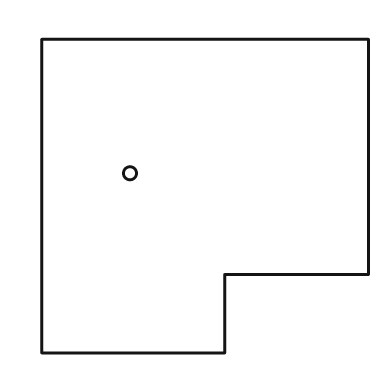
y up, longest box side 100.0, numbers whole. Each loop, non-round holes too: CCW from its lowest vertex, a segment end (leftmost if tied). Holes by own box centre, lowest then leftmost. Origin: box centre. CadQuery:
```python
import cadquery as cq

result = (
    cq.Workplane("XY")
    .moveTo(-50.0, -48.0)
    .lineTo(6.0, -48.0)
    .lineTo(6.0, -24.0)
    .lineTo(50.0, -24.0)
    .lineTo(50.0, 48.0)
    .lineTo(-50.0, 48.0)
    .close()
    .moveTo(-23.0, 7.0)
    .circle(2.0)
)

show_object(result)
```